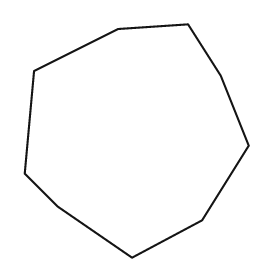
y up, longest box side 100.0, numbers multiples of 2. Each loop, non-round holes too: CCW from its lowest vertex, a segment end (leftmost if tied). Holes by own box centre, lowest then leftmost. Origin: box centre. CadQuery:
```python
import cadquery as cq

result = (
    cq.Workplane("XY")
    .moveTo(-2.0, -50.0)
    .lineTo(28.0, -34.0)
    .lineTo(48.0, -2.0)
    .lineTo(36.0, 28.0)
    .lineTo(22.0, 50.0)
    .lineTo(-8.0, 48.0)
    .lineTo(-44.0, 30.0)
    .lineTo(-48.0, -14.0)
    .lineTo(-34.0, -28.0)
    .close()
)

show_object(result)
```